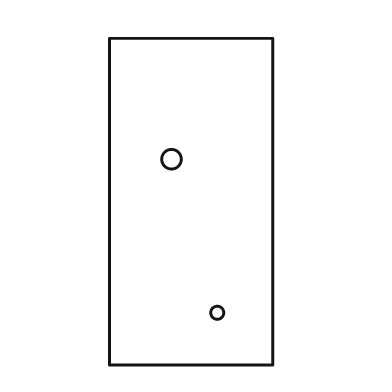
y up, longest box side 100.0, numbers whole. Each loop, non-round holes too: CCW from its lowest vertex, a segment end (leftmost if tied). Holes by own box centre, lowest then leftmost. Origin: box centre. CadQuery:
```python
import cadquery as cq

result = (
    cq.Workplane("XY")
    .moveTo(-25.0, -50.0)
    .lineTo(25.0, -50.0)
    .lineTo(25.0, 50.0)
    .lineTo(-25.0, 50.0)
    .close()
    .moveTo(8.0, -34.0)
    .circle(2.0)
    .moveTo(-6.0, 13.0)
    .circle(3.0)
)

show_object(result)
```